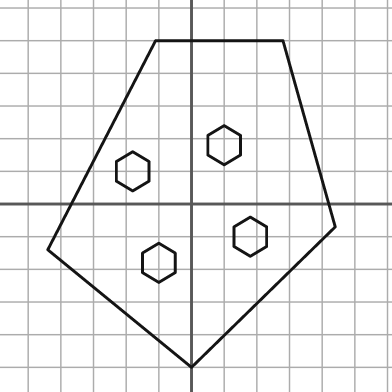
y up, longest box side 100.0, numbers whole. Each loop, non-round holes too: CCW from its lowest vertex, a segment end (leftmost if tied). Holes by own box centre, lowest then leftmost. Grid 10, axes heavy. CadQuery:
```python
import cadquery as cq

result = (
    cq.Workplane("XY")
    .moveTo(0.0, -50.0)
    .lineTo(44.0, -7.0)
    .lineTo(28.0, 50.0)
    .lineTo(-11.0, 50.0)
    .lineTo(-44.0, -14.0)
    .close()
    .moveTo(-10.0, -24.0)
    .lineTo(-5.0, -21.0)
    .lineTo(-5.0, -15.0)
    .lineTo(-10.0, -12.0)
    .lineTo(-15.0, -15.0)
    .lineTo(-15.0, -21.0)
    .close()
    .moveTo(18.0, -16.0)
    .lineTo(23.0, -13.0)
    .lineTo(23.0, -7.0)
    .lineTo(18.0, -4.0)
    .lineTo(13.0, -7.0)
    .lineTo(13.0, -13.0)
    .close()
    .moveTo(-18.0, 4.0)
    .lineTo(-13.0, 7.0)
    .lineTo(-13.0, 13.0)
    .lineTo(-18.0, 16.0)
    .lineTo(-23.0, 13.0)
    .lineTo(-23.0, 7.0)
    .close()
    .moveTo(10.0, 12.0)
    .lineTo(15.0, 15.0)
    .lineTo(15.0, 21.0)
    .lineTo(10.0, 24.0)
    .lineTo(5.0, 21.0)
    .lineTo(5.0, 15.0)
    .close()
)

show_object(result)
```